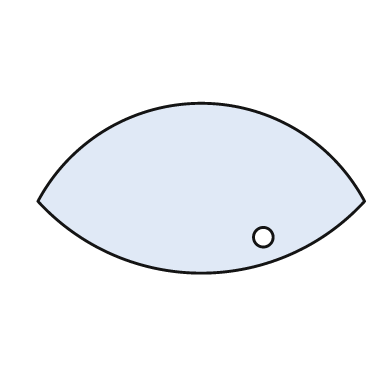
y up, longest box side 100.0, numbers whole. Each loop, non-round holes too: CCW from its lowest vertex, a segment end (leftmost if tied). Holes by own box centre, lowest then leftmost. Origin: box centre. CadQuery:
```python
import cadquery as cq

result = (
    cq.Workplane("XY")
    .moveTo(-50.0, -4.0)
    .threePointArc((0.0, -26.0), (50.0, -4.0))
    .threePointArc((0.0, 26.0), (-50.0, -4.0))
    .close()
    .moveTo(19.0, -15.0)
    .circle(3.0)
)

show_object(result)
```